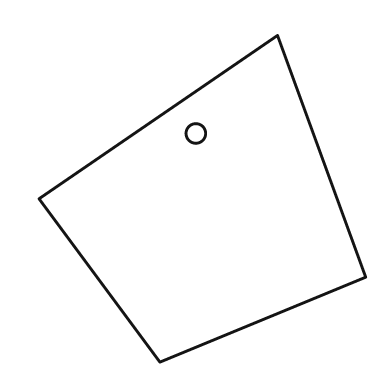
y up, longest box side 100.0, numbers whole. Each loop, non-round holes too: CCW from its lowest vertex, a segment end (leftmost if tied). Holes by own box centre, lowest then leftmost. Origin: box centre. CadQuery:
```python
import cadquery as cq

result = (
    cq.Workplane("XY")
    .moveTo(-13.0, -50.0)
    .lineTo(50.0, -24.0)
    .lineTo(23.0, 50.0)
    .lineTo(-50.0, 0.0)
    .close()
    .moveTo(-2.0, 20.0)
    .circle(3.0)
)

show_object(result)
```